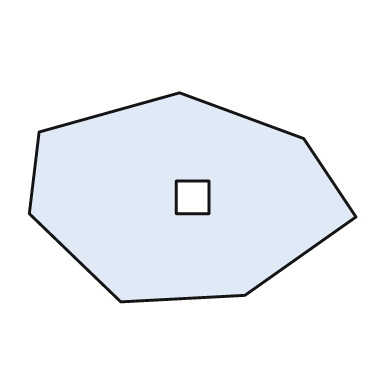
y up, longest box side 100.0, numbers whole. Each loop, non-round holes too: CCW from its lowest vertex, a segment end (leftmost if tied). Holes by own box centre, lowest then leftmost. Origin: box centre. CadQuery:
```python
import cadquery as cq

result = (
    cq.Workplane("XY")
    .moveTo(-22.0, -32.0)
    .lineTo(16.0, -30.0)
    .lineTo(50.0, -6.0)
    .lineTo(34.0, 18.0)
    .lineTo(-4.0, 32.0)
    .lineTo(-47.0, 20.0)
    .lineTo(-50.0, -5.0)
    .close()
    .moveTo(-5.0, -5.0)
    .lineTo(5.0, -5.0)
    .lineTo(5.0, 5.0)
    .lineTo(-5.0, 5.0)
    .close()
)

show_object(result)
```